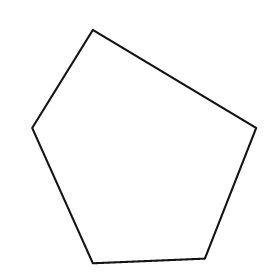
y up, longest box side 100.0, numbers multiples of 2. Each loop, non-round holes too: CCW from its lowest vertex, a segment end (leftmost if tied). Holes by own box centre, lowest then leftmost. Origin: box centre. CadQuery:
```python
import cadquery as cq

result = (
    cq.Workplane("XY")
    .moveTo(-22.0, -50.0)
    .lineTo(26.0, -48.0)
    .lineTo(48.0, 8.0)
    .lineTo(-22.0, 50.0)
    .lineTo(-48.0, 8.0)
    .close()
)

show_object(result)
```